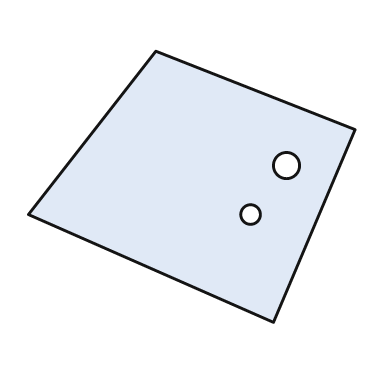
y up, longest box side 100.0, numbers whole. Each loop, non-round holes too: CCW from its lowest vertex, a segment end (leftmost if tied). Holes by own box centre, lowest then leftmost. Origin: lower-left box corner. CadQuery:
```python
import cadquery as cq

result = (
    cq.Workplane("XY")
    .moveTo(75.0, 0.0)
    .lineTo(100.0, 59.0)
    .lineTo(39.0, 83.0)
    .lineTo(0.0, 33.0)
    .close()
    .moveTo(68.0, 33.0)
    .circle(3.0)
    .moveTo(79.0, 48.0)
    .circle(4.0)
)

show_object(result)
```